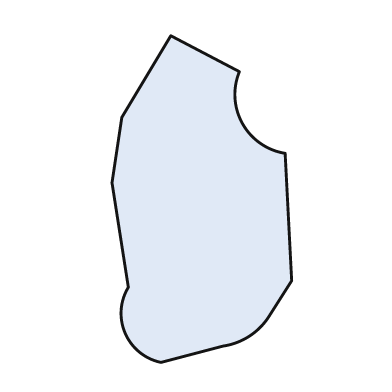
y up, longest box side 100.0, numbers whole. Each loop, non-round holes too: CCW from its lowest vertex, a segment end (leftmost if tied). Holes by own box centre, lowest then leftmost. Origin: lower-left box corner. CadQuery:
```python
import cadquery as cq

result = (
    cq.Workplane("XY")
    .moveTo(15.0, 0.0)
    .lineTo(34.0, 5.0)
    .threePointArc((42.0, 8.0), (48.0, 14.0))
    .lineTo(55.0, 25.0)
    .lineTo(53.0, 64.0)
    .threePointArc((40.0, 73.0), (39.0, 89.0))
    .lineTo(18.0, 100.0)
    .lineTo(3.0, 75.0)
    .lineTo(0.0, 55.0)
    .lineTo(5.0, 23.0)
    .threePointArc((4.0, 9.0), (15.0, 0.0))
    .close()
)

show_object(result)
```